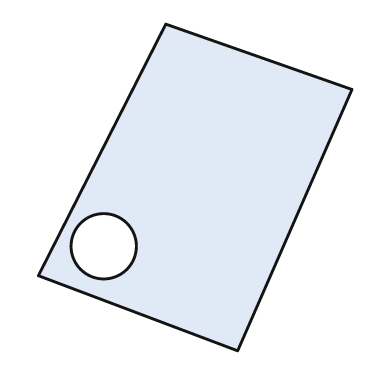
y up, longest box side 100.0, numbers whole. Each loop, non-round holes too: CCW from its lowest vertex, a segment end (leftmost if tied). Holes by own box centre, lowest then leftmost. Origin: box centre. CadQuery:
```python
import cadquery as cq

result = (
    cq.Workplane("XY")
    .moveTo(13.0, -50.0)
    .lineTo(48.0, 30.0)
    .lineTo(-9.0, 50.0)
    .lineTo(-48.0, -27.0)
    .close()
    .moveTo(-28.0, -18.0)
    .circle(10.0)
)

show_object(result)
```